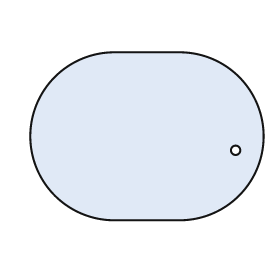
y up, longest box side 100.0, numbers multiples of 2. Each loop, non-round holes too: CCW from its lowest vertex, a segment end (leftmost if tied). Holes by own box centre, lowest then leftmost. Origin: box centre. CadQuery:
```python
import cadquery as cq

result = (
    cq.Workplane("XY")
    .moveTo(-14.0, -36.0)
    .lineTo(14.0, -36.0)
    .threePointArc((50.0, 0.0), (14.0, 36.0))
    .lineTo(-14.0, 36.0)
    .threePointArc((-50.0, 0.0), (-14.0, -36.0))
    .close()
    .moveTo(38.0, -6.0)
    .circle(2.0)
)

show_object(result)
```